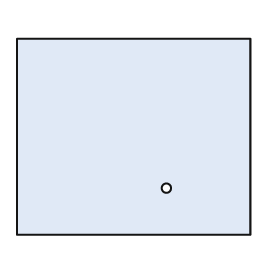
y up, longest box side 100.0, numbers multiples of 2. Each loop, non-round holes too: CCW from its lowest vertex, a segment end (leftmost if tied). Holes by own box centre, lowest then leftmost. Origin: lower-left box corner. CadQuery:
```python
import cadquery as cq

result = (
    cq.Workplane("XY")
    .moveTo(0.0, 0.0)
    .lineTo(100.0, 0.0)
    .lineTo(100.0, 84.0)
    .lineTo(0.0, 84.0)
    .close()
    .moveTo(64.0, 20.0)
    .circle(2.0)
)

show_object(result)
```